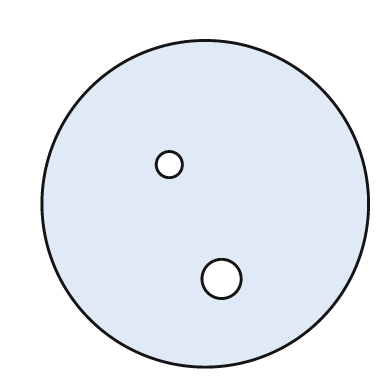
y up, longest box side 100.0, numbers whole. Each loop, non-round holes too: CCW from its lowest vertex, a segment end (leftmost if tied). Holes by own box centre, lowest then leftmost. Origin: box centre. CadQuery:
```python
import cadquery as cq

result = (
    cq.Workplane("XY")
    .moveTo(0.0, 0.0)
    .circle(50.0)
    .moveTo(5.0, -23.0)
    .circle(6.0)
    .moveTo(-11.0, 12.0)
    .circle(4.0)
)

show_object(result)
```